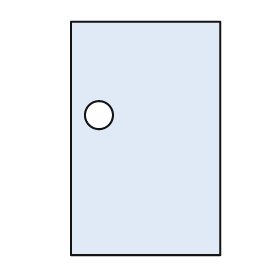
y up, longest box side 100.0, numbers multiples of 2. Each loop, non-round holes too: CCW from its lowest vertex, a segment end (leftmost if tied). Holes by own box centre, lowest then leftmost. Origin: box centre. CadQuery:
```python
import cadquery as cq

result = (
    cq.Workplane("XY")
    .moveTo(-32.0, -50.0)
    .lineTo(32.0, -50.0)
    .lineTo(32.0, 50.0)
    .lineTo(-32.0, 50.0)
    .close()
    .moveTo(-20.0, 10.0)
    .circle(6.0)
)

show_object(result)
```